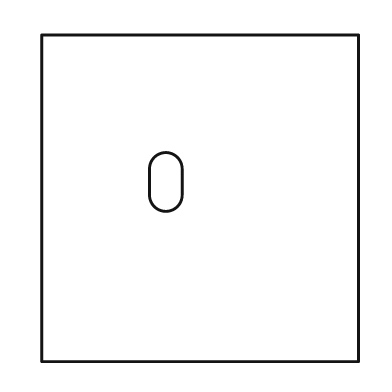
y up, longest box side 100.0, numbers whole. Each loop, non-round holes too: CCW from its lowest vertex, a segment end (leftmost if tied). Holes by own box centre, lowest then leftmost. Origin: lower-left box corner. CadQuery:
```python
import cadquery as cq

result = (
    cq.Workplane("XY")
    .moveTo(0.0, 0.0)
    .lineTo(97.0, 0.0)
    .lineTo(97.0, 100.0)
    .lineTo(0.0, 100.0)
    .close()
    .moveTo(33.0, 51.0)
    .threePointArc((38.0, 46.0), (43.0, 51.0))
    .lineTo(43.0, 59.0)
    .threePointArc((38.0, 64.0), (33.0, 59.0))
    .close()
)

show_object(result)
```